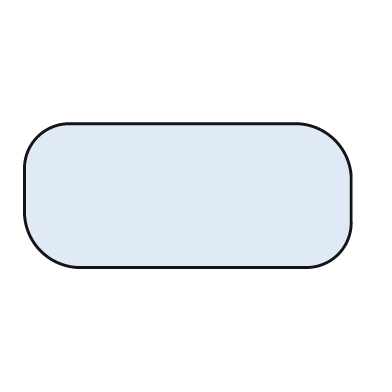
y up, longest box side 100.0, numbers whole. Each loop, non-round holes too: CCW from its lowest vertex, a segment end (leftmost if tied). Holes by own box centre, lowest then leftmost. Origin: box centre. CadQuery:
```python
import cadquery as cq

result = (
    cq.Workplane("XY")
    .moveTo(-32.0, -22.0)
    .lineTo(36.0, -22.0)
    .threePointArc((46.0, -18.0), (50.0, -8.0))
    .lineTo(50.0, 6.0)
    .threePointArc((45.0, 17.0), (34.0, 22.0))
    .lineTo(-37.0, 22.0)
    .threePointArc((-46.0, 18.0), (-50.0, 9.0))
    .lineTo(-50.0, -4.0)
    .threePointArc((-45.0, -17.0), (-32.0, -22.0))
    .close()
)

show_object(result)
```